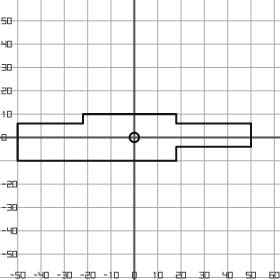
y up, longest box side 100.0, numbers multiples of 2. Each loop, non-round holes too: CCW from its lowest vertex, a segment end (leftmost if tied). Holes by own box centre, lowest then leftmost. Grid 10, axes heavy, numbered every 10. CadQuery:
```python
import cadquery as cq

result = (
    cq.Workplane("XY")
    .moveTo(-50.0, -10.0)
    .lineTo(18.0, -10.0)
    .lineTo(18.0, -4.0)
    .lineTo(50.0, -4.0)
    .lineTo(50.0, 6.0)
    .lineTo(18.0, 6.0)
    .lineTo(18.0, 10.0)
    .lineTo(-22.0, 10.0)
    .lineTo(-22.0, 6.0)
    .lineTo(-50.0, 6.0)
    .close()
    .moveTo(0.0, 0.0)
    .circle(2.0)
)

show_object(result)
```